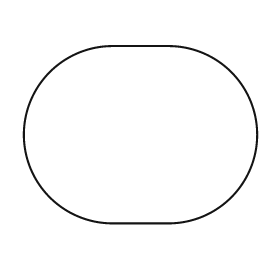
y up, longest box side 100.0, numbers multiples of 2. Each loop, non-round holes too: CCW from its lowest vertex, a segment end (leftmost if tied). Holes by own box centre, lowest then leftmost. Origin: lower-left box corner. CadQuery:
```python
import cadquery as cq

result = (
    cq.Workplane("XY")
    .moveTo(38.0, 0.0)
    .lineTo(62.0, 0.0)
    .threePointArc((100.0, 38.0), (62.0, 76.0))
    .lineTo(38.0, 76.0)
    .threePointArc((0.0, 38.0), (38.0, 0.0))
    .close()
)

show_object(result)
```